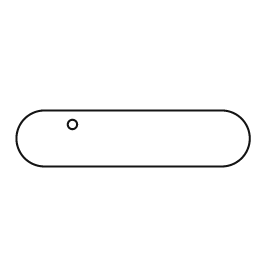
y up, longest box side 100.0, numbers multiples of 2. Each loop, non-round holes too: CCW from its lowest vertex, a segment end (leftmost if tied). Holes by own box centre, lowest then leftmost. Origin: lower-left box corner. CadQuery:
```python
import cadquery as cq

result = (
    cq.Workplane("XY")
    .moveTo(12.0, 0.0)
    .lineTo(88.0, 0.0)
    .threePointArc((100.0, 12.0), (88.0, 24.0))
    .lineTo(12.0, 24.0)
    .threePointArc((0.0, 12.0), (12.0, 0.0))
    .close()
    .moveTo(24.0, 18.0)
    .circle(2.0)
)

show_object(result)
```